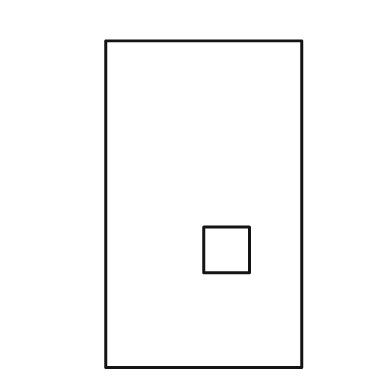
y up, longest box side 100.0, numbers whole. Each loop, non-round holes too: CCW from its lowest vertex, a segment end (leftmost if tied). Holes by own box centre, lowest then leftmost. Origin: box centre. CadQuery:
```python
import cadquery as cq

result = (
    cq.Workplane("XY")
    .moveTo(-30.0, -50.0)
    .lineTo(30.0, -50.0)
    .lineTo(30.0, 50.0)
    .lineTo(-30.0, 50.0)
    .close()
    .moveTo(0.0, -21.0)
    .lineTo(14.0, -21.0)
    .lineTo(14.0, -7.0)
    .lineTo(0.0, -7.0)
    .close()
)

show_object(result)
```